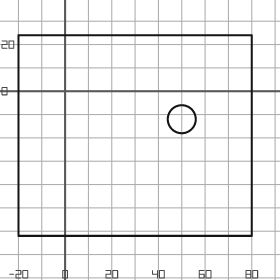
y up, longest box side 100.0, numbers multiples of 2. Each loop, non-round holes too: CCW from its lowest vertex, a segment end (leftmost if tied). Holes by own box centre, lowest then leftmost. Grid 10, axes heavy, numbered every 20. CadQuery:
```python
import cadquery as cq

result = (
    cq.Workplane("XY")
    .moveTo(-20.0, -62.0)
    .lineTo(80.0, -62.0)
    .lineTo(80.0, 24.0)
    .lineTo(-20.0, 24.0)
    .close()
    .moveTo(50.0, -12.0)
    .circle(6.0)
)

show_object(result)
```